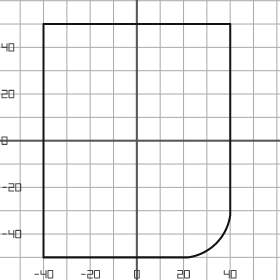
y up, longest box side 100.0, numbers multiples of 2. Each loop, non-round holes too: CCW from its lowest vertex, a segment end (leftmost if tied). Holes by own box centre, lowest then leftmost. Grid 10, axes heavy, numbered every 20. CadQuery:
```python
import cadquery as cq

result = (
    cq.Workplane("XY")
    .moveTo(-40.0, -50.0)
    .lineTo(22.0, -50.0)
    .threePointArc((34.0, -44.0), (40.0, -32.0))
    .lineTo(40.0, 50.0)
    .lineTo(-40.0, 50.0)
    .close()
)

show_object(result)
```